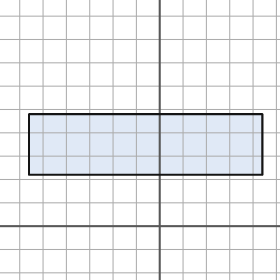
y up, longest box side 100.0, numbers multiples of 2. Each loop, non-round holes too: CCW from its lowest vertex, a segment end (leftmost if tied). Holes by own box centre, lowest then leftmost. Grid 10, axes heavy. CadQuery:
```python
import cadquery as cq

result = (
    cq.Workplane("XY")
    .moveTo(-56.0, 22.0)
    .lineTo(44.0, 22.0)
    .lineTo(44.0, 48.0)
    .lineTo(-56.0, 48.0)
    .close()
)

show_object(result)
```